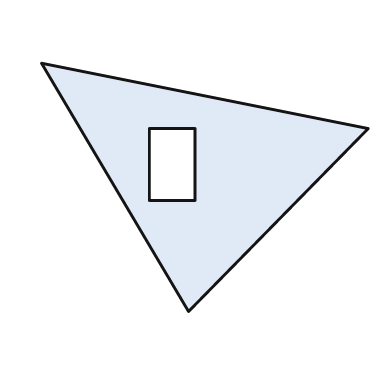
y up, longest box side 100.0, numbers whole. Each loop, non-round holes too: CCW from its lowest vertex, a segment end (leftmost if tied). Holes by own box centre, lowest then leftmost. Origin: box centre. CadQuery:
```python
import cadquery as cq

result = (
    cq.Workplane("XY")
    .moveTo(-5.0, -38.0)
    .lineTo(50.0, 18.0)
    .lineTo(-50.0, 38.0)
    .close()
    .moveTo(-17.0, -4.0)
    .lineTo(-3.0, -4.0)
    .lineTo(-3.0, 18.0)
    .lineTo(-17.0, 18.0)
    .close()
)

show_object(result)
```